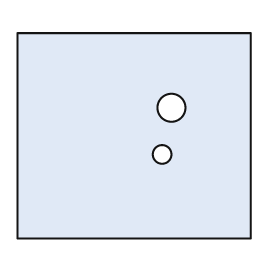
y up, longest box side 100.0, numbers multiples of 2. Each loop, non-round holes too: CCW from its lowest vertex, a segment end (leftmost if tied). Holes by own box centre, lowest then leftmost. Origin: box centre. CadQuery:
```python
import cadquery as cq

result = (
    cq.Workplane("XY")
    .moveTo(-50.0, -44.0)
    .lineTo(50.0, -44.0)
    .lineTo(50.0, 44.0)
    .lineTo(-50.0, 44.0)
    .close()
    .moveTo(12.0, -8.0)
    .circle(4.0)
    .moveTo(16.0, 12.0)
    .circle(6.0)
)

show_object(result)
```